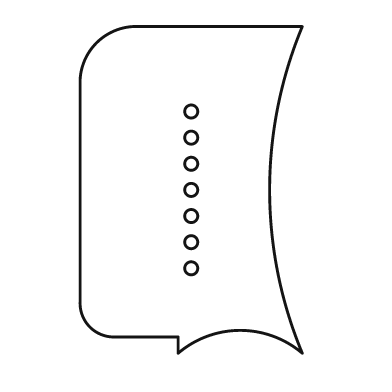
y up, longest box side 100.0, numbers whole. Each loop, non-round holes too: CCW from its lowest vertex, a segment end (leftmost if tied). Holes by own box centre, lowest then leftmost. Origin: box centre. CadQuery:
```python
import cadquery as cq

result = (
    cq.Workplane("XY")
    .moveTo(-4.0, -50.0)
    .threePointArc((15.0, -43.0), (34.0, -50.0))
    .threePointArc((24.0, 0.0), (34.0, 50.0))
    .lineTo(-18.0, 50.0)
    .threePointArc((-29.0, 45.0), (-34.0, 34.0))
    .lineTo(-34.0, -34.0)
    .threePointArc((-31.0, -42.0), (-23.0, -45.0))
    .lineTo(-4.0, -45.0)
    .close()
    .moveTo(0.0, -24.0)
    .circle(2.0)
    .moveTo(0.0, -16.0)
    .circle(2.0)
    .moveTo(0.0, -8.0)
    .circle(2.0)
    .moveTo(0.0, 0.0)
    .circle(2.0)
    .moveTo(0.0, 8.0)
    .circle(2.0)
    .moveTo(0.0, 16.0)
    .circle(2.0)
    .moveTo(0.0, 24.0)
    .circle(2.0)
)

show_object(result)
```